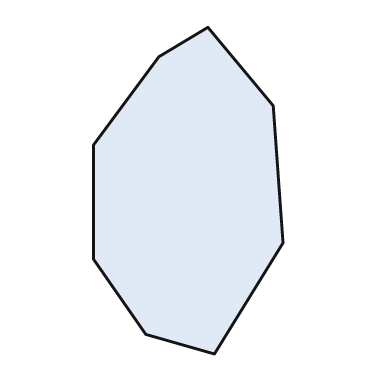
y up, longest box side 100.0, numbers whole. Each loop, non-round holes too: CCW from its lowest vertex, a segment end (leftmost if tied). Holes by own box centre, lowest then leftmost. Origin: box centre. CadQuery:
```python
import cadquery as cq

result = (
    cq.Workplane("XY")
    .moveTo(8.0, -50.0)
    .lineTo(29.0, -16.0)
    .lineTo(26.0, 26.0)
    .lineTo(6.0, 50.0)
    .lineTo(-9.0, 41.0)
    .lineTo(-29.0, 14.0)
    .lineTo(-29.0, -21.0)
    .lineTo(-13.0, -44.0)
    .close()
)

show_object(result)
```